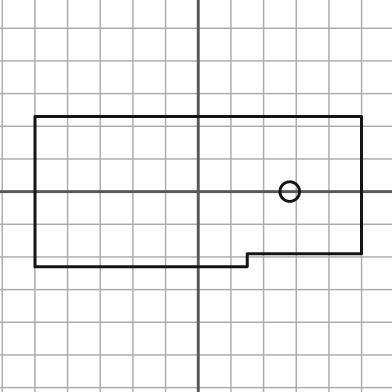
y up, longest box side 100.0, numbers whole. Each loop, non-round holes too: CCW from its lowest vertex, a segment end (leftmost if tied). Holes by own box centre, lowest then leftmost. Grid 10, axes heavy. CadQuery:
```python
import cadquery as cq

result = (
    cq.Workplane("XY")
    .moveTo(-50.0, -23.0)
    .lineTo(15.0, -23.0)
    .lineTo(15.0, -19.0)
    .lineTo(50.0, -19.0)
    .lineTo(50.0, 23.0)
    .lineTo(-50.0, 23.0)
    .close()
    .moveTo(28.0, 0.0)
    .circle(3.0)
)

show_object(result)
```